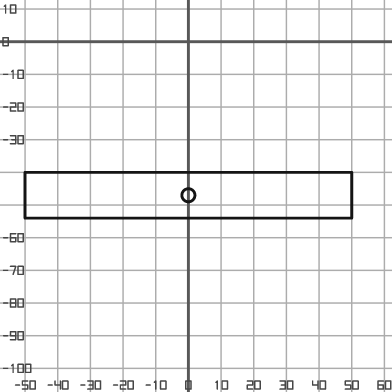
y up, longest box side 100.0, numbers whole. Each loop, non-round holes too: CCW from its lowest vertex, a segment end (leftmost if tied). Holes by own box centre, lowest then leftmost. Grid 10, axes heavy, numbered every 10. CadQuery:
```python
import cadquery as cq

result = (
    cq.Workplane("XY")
    .moveTo(-50.0, -54.0)
    .lineTo(50.0, -54.0)
    .lineTo(50.0, -40.0)
    .lineTo(-50.0, -40.0)
    .close()
    .moveTo(0.0, -47.0)
    .circle(2.0)
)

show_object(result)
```